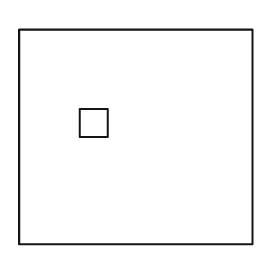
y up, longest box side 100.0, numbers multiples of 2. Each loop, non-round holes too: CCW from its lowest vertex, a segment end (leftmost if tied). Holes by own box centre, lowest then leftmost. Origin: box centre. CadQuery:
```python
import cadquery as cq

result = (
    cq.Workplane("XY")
    .moveTo(-50.0, -46.0)
    .lineTo(50.0, -46.0)
    .lineTo(50.0, 46.0)
    .lineTo(-50.0, 46.0)
    .close()
    .moveTo(-24.0, 0.0)
    .lineTo(-12.0, 0.0)
    .lineTo(-12.0, 12.0)
    .lineTo(-24.0, 12.0)
    .close()
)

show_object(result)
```